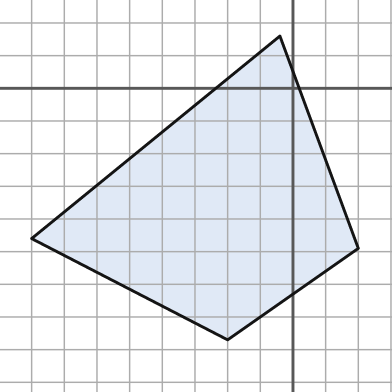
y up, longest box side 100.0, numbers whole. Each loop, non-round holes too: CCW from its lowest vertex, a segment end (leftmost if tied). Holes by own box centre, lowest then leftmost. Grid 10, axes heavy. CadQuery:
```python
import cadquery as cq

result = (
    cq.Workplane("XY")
    .moveTo(-20.0, -77.0)
    .lineTo(20.0, -49.0)
    .lineTo(-4.0, 16.0)
    .lineTo(-80.0, -46.0)
    .close()
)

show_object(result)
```